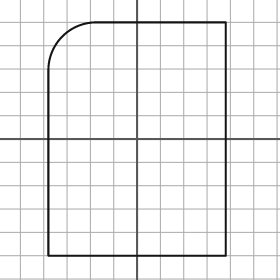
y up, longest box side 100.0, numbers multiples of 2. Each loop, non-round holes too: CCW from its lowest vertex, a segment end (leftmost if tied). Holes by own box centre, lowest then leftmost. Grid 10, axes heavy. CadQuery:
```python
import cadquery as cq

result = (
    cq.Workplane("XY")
    .moveTo(-38.0, -50.0)
    .lineTo(38.0, -50.0)
    .lineTo(38.0, 50.0)
    .lineTo(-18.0, 50.0)
    .threePointArc((-32.0, 44.0), (-38.0, 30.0))
    .close()
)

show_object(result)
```